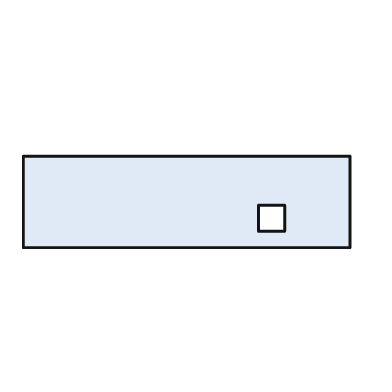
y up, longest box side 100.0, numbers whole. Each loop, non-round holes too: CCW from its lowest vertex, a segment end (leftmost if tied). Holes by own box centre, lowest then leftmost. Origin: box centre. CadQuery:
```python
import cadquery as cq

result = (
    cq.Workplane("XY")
    .moveTo(-50.0, -14.0)
    .lineTo(50.0, -14.0)
    .lineTo(50.0, 14.0)
    .lineTo(-50.0, 14.0)
    .close()
    .moveTo(22.0, -9.0)
    .lineTo(30.0, -9.0)
    .lineTo(30.0, -1.0)
    .lineTo(22.0, -1.0)
    .close()
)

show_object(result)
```